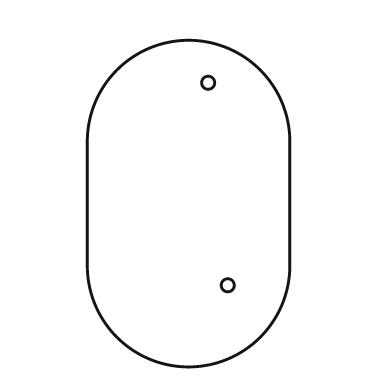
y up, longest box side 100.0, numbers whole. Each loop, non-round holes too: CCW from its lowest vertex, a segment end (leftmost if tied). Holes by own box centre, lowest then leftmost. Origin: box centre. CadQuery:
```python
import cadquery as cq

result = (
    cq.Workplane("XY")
    .moveTo(-31.0, -19.0)
    .threePointArc((0.0, -50.0), (31.0, -19.0))
    .lineTo(31.0, 19.0)
    .threePointArc((0.0, 50.0), (-31.0, 19.0))
    .close()
    .moveTo(12.0, -25.0)
    .circle(2.0)
    .moveTo(6.0, 37.0)
    .circle(2.0)
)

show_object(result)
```